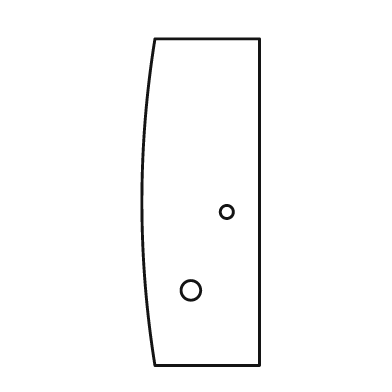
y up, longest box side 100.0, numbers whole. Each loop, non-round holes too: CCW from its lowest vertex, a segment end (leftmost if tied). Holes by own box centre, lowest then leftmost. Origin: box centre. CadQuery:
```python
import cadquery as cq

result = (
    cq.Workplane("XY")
    .moveTo(-14.0, -50.0)
    .lineTo(18.0, -50.0)
    .lineTo(18.0, 50.0)
    .lineTo(-14.0, 50.0)
    .threePointArc((-18.0, 0.0), (-14.0, -50.0))
    .close()
    .moveTo(-3.0, -27.0)
    .circle(3.0)
    .moveTo(8.0, -3.0)
    .circle(2.0)
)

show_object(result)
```